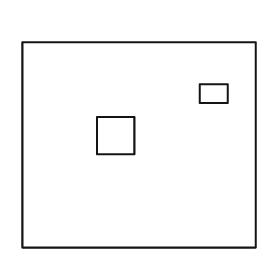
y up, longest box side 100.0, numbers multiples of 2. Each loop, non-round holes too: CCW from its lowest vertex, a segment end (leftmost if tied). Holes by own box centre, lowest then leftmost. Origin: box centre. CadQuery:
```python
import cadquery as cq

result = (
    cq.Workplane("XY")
    .moveTo(-50.0, -44.0)
    .lineTo(50.0, -44.0)
    .lineTo(50.0, 44.0)
    .lineTo(-50.0, 44.0)
    .close()
    .moveTo(-18.0, -4.0)
    .lineTo(-2.0, -4.0)
    .lineTo(-2.0, 12.0)
    .lineTo(-18.0, 12.0)
    .close()
    .moveTo(26.0, 18.0)
    .lineTo(38.0, 18.0)
    .lineTo(38.0, 26.0)
    .lineTo(26.0, 26.0)
    .close()
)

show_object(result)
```